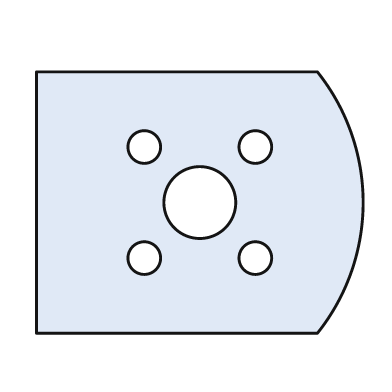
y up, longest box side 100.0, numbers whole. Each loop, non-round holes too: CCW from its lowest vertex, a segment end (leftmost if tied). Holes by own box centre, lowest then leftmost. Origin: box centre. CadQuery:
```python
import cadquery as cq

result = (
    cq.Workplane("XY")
    .moveTo(-50.0, -40.0)
    .lineTo(36.0, -40.0)
    .threePointArc((50.0, 0.0), (36.0, 40.0))
    .lineTo(-50.0, 40.0)
    .close()
    .moveTo(-17.0, -17.0)
    .circle(5.0)
    .moveTo(17.0, -17.0)
    .circle(5.0)
    .moveTo(0.0, 0.0)
    .circle(11.0)
    .moveTo(-17.0, 17.0)
    .circle(5.0)
    .moveTo(17.0, 17.0)
    .circle(5.0)
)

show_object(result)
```